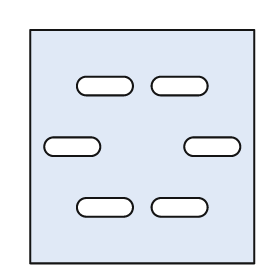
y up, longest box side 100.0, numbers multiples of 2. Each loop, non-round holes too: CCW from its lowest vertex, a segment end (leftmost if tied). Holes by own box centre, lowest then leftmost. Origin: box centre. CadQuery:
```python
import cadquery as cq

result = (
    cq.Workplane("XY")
    .moveTo(-48.0, -50.0)
    .lineTo(48.0, -50.0)
    .lineTo(48.0, 50.0)
    .lineTo(-48.0, 50.0)
    .close()
    .moveTo(-24.0, -30.0)
    .lineTo(-8.0, -30.0)
    .threePointArc((-4.0, -26.0), (-8.0, -22.0))
    .lineTo(-24.0, -22.0)
    .threePointArc((-28.0, -26.0), (-24.0, -30.0))
    .close()
    .moveTo(8.0, -30.0)
    .lineTo(24.0, -30.0)
    .threePointArc((28.0, -26.0), (24.0, -22.0))
    .lineTo(8.0, -22.0)
    .threePointArc((4.0, -26.0), (8.0, -30.0))
    .close()
    .moveTo(-38.0, -4.0)
    .lineTo(-22.0, -4.0)
    .threePointArc((-18.0, 0.0), (-22.0, 4.0))
    .lineTo(-38.0, 4.0)
    .threePointArc((-42.0, 0.0), (-38.0, -4.0))
    .close()
    .moveTo(22.0, -4.0)
    .lineTo(38.0, -4.0)
    .threePointArc((42.0, 0.0), (38.0, 4.0))
    .lineTo(22.0, 4.0)
    .threePointArc((18.0, 0.0), (22.0, -4.0))
    .close()
    .moveTo(-24.0, 22.0)
    .lineTo(-8.0, 22.0)
    .threePointArc((-4.0, 26.0), (-8.0, 30.0))
    .lineTo(-24.0, 30.0)
    .threePointArc((-28.0, 26.0), (-24.0, 22.0))
    .close()
    .moveTo(8.0, 22.0)
    .lineTo(24.0, 22.0)
    .threePointArc((28.0, 26.0), (24.0, 30.0))
    .lineTo(8.0, 30.0)
    .threePointArc((4.0, 26.0), (8.0, 22.0))
    .close()
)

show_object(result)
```